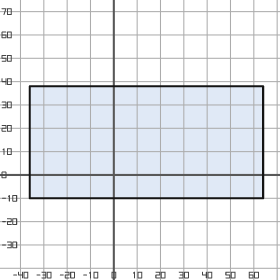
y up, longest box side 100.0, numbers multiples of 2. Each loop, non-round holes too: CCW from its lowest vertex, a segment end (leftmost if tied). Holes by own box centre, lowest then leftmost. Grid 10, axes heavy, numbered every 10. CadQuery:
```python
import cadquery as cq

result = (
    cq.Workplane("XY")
    .moveTo(-36.0, -10.0)
    .lineTo(64.0, -10.0)
    .lineTo(64.0, 38.0)
    .lineTo(-36.0, 38.0)
    .close()
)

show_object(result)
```